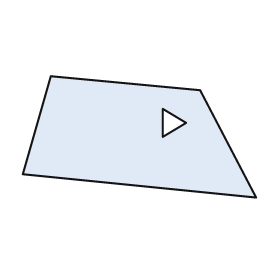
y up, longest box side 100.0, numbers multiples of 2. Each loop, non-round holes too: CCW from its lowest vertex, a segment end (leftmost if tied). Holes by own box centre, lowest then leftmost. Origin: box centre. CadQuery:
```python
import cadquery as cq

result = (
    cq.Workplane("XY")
    .moveTo(50.0, -26.0)
    .lineTo(26.0, 20.0)
    .lineTo(-38.0, 26.0)
    .lineTo(-50.0, -16.0)
    .close()
    .moveTo(10.0, 0.0)
    .lineTo(20.0, 6.0)
    .lineTo(10.0, 12.0)
    .close()
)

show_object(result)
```